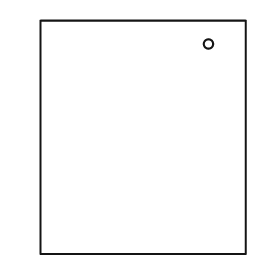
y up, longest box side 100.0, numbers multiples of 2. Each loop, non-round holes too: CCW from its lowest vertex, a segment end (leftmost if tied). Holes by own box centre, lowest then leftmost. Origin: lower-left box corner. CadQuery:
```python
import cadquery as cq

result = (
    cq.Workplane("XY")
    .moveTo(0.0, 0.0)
    .lineTo(88.0, 0.0)
    .lineTo(88.0, 100.0)
    .lineTo(0.0, 100.0)
    .close()
    .moveTo(72.0, 90.0)
    .circle(2.0)
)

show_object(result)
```